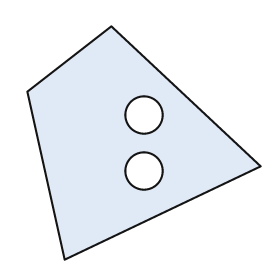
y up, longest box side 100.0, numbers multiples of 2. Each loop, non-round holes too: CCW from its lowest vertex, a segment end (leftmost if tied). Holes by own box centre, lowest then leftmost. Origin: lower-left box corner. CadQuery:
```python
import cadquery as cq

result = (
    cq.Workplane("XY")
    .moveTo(16.0, 0.0)
    .lineTo(100.0, 40.0)
    .lineTo(36.0, 100.0)
    .lineTo(0.0, 72.0)
    .close()
    .moveTo(50.0, 38.0)
    .circle(8.0)
    .moveTo(50.0, 62.0)
    .circle(8.0)
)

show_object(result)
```